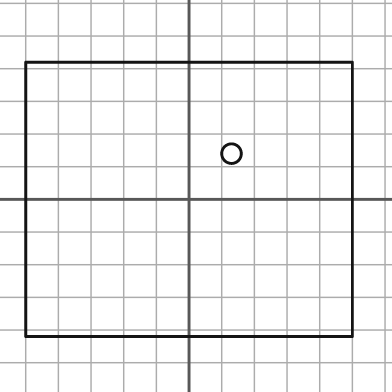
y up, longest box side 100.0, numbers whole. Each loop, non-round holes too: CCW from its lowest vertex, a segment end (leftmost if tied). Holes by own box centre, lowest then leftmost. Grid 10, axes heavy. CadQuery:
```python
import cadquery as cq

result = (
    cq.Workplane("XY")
    .moveTo(-50.0, -42.0)
    .lineTo(50.0, -42.0)
    .lineTo(50.0, 42.0)
    .lineTo(-50.0, 42.0)
    .close()
    .moveTo(13.0, 14.0)
    .circle(3.0)
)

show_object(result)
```